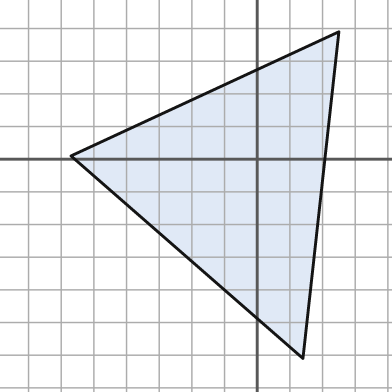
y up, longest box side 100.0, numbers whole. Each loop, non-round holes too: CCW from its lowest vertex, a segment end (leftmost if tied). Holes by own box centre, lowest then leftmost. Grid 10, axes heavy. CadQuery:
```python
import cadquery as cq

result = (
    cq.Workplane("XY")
    .moveTo(14.0, -61.0)
    .lineTo(25.0, 39.0)
    .lineTo(-57.0, 1.0)
    .close()
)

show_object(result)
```